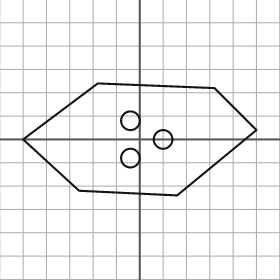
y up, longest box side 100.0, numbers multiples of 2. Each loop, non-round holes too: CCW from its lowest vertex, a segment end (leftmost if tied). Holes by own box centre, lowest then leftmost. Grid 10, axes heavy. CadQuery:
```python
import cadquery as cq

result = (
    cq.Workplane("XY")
    .moveTo(16.0, -24.0)
    .lineTo(50.0, 4.0)
    .lineTo(32.0, 22.0)
    .lineTo(-18.0, 24.0)
    .lineTo(-50.0, 0.0)
    .lineTo(-26.0, -22.0)
    .close()
    .moveTo(-4.0, -8.0)
    .circle(4.0)
    .moveTo(10.0, 0.0)
    .circle(4.0)
    .moveTo(-4.0, 8.0)
    .circle(4.0)
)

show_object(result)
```